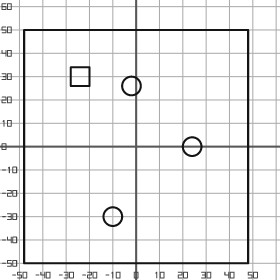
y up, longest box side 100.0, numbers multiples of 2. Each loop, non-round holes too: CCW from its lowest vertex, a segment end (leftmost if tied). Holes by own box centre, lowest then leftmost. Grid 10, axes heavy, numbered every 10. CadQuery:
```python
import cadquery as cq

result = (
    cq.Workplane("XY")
    .moveTo(-48.0, -50.0)
    .lineTo(48.0, -50.0)
    .lineTo(48.0, 50.0)
    .lineTo(-48.0, 50.0)
    .close()
    .moveTo(-10.0, -30.0)
    .circle(4.0)
    .moveTo(24.0, 0.0)
    .circle(4.0)
    .moveTo(-2.0, 26.0)
    .circle(4.0)
    .moveTo(-28.0, 26.0)
    .lineTo(-20.0, 26.0)
    .lineTo(-20.0, 34.0)
    .lineTo(-28.0, 34.0)
    .close()
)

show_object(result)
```